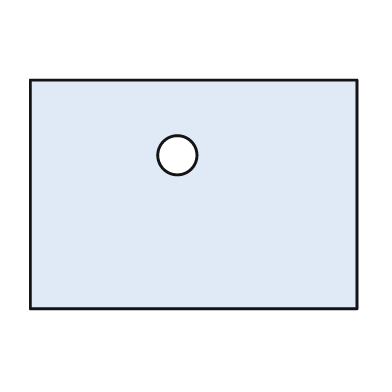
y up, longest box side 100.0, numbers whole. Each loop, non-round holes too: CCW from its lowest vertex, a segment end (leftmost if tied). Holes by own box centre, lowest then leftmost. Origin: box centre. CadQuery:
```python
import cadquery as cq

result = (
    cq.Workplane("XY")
    .moveTo(-50.0, -35.0)
    .lineTo(50.0, -35.0)
    .lineTo(50.0, 35.0)
    .lineTo(-50.0, 35.0)
    .close()
    .moveTo(-5.0, 12.0)
    .circle(6.0)
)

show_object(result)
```